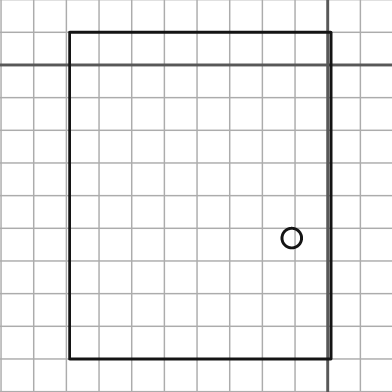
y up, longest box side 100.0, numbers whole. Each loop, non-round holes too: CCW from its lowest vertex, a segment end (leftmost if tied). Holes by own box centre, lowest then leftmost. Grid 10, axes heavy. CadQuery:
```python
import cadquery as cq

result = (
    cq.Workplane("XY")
    .moveTo(-79.0, -90.0)
    .lineTo(1.0, -90.0)
    .lineTo(1.0, 10.0)
    .lineTo(-79.0, 10.0)
    .close()
    .moveTo(-11.0, -53.0)
    .circle(3.0)
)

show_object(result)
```